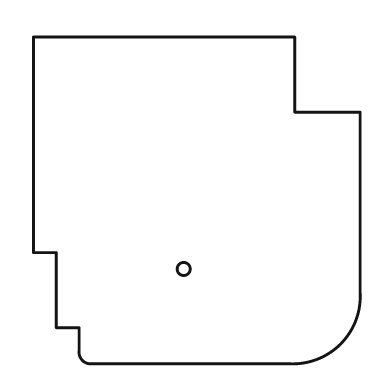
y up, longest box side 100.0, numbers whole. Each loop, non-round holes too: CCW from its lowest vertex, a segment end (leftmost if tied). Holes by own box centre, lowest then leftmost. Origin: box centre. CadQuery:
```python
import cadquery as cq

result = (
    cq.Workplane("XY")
    .moveTo(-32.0, -50.0)
    .lineTo(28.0, -50.0)
    .threePointArc((44.0, -44.0), (50.0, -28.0))
    .lineTo(50.0, 27.0)
    .lineTo(30.0, 27.0)
    .lineTo(30.0, 50.0)
    .lineTo(-50.0, 50.0)
    .lineTo(-50.0, -16.0)
    .lineTo(-43.0, -16.0)
    .lineTo(-43.0, -39.0)
    .lineTo(-36.0, -39.0)
    .lineTo(-36.0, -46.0)
    .threePointArc((-35.0, -49.0), (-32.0, -50.0))
    .close()
    .moveTo(-4.0, -21.0)
    .circle(2.0)
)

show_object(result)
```